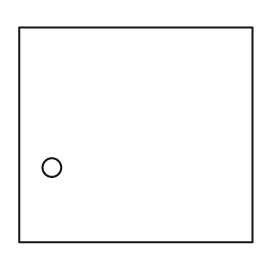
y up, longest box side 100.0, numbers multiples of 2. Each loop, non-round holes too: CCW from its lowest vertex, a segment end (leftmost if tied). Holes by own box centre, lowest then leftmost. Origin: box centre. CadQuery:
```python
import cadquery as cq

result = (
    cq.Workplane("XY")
    .moveTo(-50.0, -46.0)
    .lineTo(50.0, -46.0)
    .lineTo(50.0, 46.0)
    .lineTo(-50.0, 46.0)
    .close()
    .moveTo(-36.0, -14.0)
    .circle(4.0)
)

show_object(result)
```